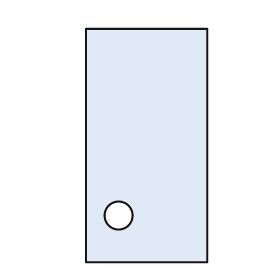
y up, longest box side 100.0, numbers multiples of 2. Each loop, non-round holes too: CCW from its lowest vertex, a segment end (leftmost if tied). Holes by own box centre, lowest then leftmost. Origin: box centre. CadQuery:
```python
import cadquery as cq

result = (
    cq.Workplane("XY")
    .moveTo(-26.0, -50.0)
    .lineTo(26.0, -50.0)
    .lineTo(26.0, 50.0)
    .lineTo(-26.0, 50.0)
    .close()
    .moveTo(-12.0, -30.0)
    .circle(6.0)
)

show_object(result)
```